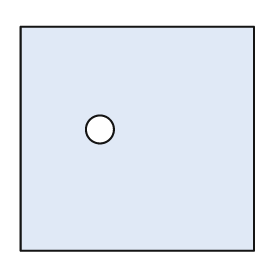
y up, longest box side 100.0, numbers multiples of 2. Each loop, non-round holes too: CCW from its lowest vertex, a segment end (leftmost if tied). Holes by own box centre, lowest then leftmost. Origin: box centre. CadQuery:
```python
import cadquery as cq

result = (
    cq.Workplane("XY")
    .moveTo(-50.0, -48.0)
    .lineTo(50.0, -48.0)
    .lineTo(50.0, 48.0)
    .lineTo(-50.0, 48.0)
    .close()
    .moveTo(-16.0, 4.0)
    .circle(6.0)
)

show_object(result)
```